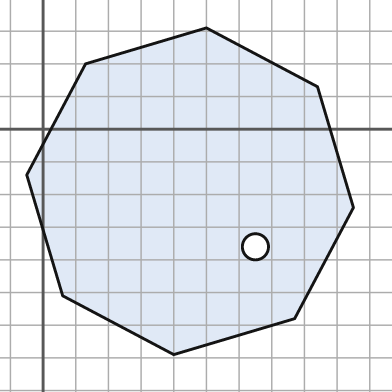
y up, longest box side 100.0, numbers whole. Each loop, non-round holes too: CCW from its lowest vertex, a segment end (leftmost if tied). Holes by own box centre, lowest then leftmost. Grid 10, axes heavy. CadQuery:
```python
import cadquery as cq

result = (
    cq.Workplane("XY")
    .moveTo(40.0, -69.0)
    .lineTo(77.0, -58.0)
    .lineTo(95.0, -24.0)
    .lineTo(84.0, 13.0)
    .lineTo(50.0, 31.0)
    .lineTo(13.0, 20.0)
    .lineTo(-5.0, -14.0)
    .lineTo(6.0, -51.0)
    .close()
    .moveTo(65.0, -36.0)
    .circle(4.0)
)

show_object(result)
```